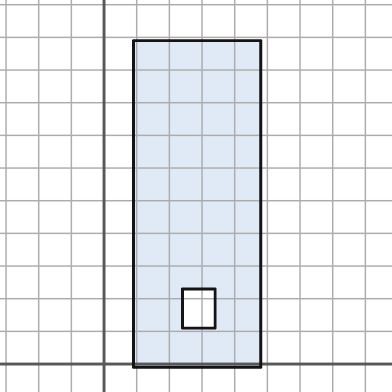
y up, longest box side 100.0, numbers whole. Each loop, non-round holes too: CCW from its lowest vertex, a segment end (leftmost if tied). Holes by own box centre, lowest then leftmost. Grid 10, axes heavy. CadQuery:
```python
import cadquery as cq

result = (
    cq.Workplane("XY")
    .moveTo(9.0, -1.0)
    .lineTo(48.0, -1.0)
    .lineTo(48.0, 99.0)
    .lineTo(9.0, 99.0)
    .close()
    .moveTo(24.0, 11.0)
    .lineTo(34.0, 11.0)
    .lineTo(34.0, 23.0)
    .lineTo(24.0, 23.0)
    .close()
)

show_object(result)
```